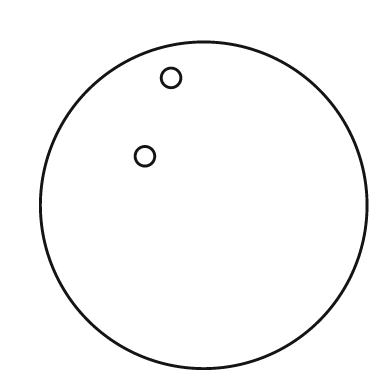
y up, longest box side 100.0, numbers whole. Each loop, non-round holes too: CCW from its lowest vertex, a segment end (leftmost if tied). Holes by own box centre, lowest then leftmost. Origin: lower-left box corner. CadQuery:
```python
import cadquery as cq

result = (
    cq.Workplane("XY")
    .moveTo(50.0, 50.0)
    .circle(50.0)
    .moveTo(32.0, 65.0)
    .circle(3.0)
    .moveTo(40.0, 89.0)
    .circle(3.0)
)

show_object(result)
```